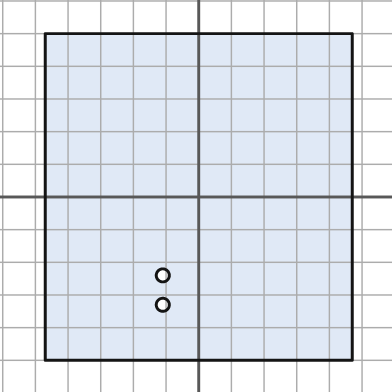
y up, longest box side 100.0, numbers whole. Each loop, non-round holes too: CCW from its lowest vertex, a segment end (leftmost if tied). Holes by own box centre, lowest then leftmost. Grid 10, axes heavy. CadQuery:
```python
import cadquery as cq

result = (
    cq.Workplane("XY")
    .moveTo(-47.0, -50.0)
    .lineTo(47.0, -50.0)
    .lineTo(47.0, 50.0)
    .lineTo(-47.0, 50.0)
    .close()
    .moveTo(-11.0, -33.0)
    .circle(2.0)
    .moveTo(-11.0, -24.0)
    .circle(2.0)
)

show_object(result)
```